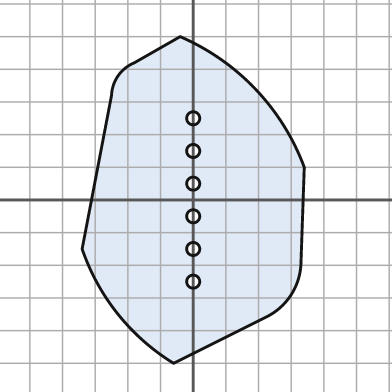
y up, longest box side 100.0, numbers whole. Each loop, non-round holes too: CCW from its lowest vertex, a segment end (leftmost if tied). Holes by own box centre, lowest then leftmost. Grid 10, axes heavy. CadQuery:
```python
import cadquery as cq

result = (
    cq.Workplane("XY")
    .moveTo(-6.0, -50.0)
    .lineTo(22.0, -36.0)
    .threePointArc((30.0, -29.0), (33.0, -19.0))
    .lineTo(34.0, 10.0)
    .threePointArc((19.0, 34.0), (-4.0, 50.0))
    .lineTo(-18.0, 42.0)
    .threePointArc((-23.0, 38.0), (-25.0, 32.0))
    .lineTo(-34.0, -15.0)
    .threePointArc((-23.0, -35.0), (-6.0, -50.0))
    .close()
    .moveTo(0.0, -25.0)
    .circle(2.0)
    .moveTo(0.0, -15.0)
    .circle(2.0)
    .moveTo(0.0, -5.0)
    .circle(2.0)
    .moveTo(0.0, 5.0)
    .circle(2.0)
    .moveTo(0.0, 15.0)
    .circle(2.0)
    .moveTo(0.0, 25.0)
    .circle(2.0)
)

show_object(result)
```